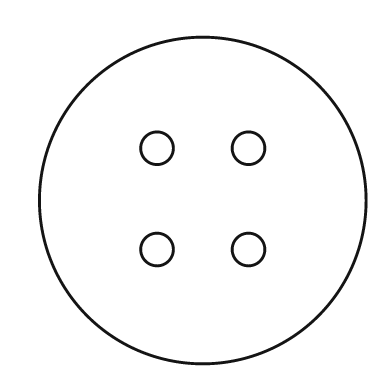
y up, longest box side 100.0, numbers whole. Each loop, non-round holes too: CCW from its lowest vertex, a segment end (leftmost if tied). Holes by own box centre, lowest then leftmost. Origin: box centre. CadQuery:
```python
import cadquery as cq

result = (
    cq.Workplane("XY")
    .moveTo(0.0, 0.0)
    .circle(50.0)
    .moveTo(-14.0, -15.0)
    .circle(5.0)
    .moveTo(14.0, -15.0)
    .circle(5.0)
    .moveTo(-14.0, 16.0)
    .circle(5.0)
    .moveTo(14.0, 16.0)
    .circle(5.0)
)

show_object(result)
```